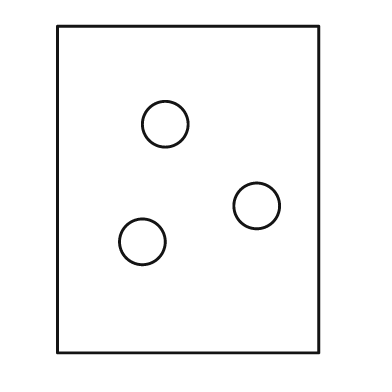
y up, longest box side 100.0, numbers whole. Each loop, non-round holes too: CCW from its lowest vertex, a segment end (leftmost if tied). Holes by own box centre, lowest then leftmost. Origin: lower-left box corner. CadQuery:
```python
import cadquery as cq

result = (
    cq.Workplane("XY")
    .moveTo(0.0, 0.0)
    .lineTo(80.0, 0.0)
    .lineTo(80.0, 100.0)
    .lineTo(0.0, 100.0)
    .close()
    .moveTo(26.0, 34.0)
    .circle(7.0)
    .moveTo(61.0, 45.0)
    .circle(7.0)
    .moveTo(33.0, 70.0)
    .circle(7.0)
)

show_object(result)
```